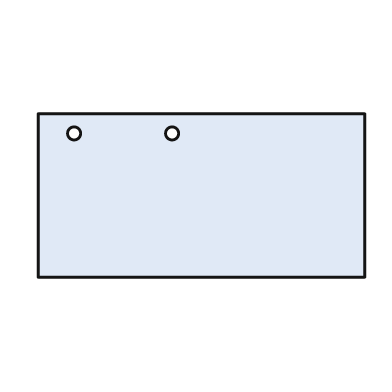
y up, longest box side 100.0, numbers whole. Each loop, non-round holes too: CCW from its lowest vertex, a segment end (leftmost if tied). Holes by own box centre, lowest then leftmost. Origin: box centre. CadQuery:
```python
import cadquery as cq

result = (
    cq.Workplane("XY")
    .moveTo(-50.0, -25.0)
    .lineTo(50.0, -25.0)
    .lineTo(50.0, 25.0)
    .lineTo(-50.0, 25.0)
    .close()
    .moveTo(-39.0, 19.0)
    .circle(2.0)
    .moveTo(-9.0, 19.0)
    .circle(2.0)
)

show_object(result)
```